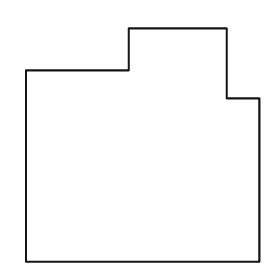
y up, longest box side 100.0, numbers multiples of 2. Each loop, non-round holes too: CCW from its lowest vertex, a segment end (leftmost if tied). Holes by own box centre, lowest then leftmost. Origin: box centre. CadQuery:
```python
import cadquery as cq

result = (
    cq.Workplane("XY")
    .moveTo(-50.0, -50.0)
    .lineTo(50.0, -50.0)
    .lineTo(50.0, 20.0)
    .lineTo(36.0, 20.0)
    .lineTo(36.0, 50.0)
    .lineTo(-6.0, 50.0)
    .lineTo(-6.0, 32.0)
    .lineTo(-50.0, 32.0)
    .close()
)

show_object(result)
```